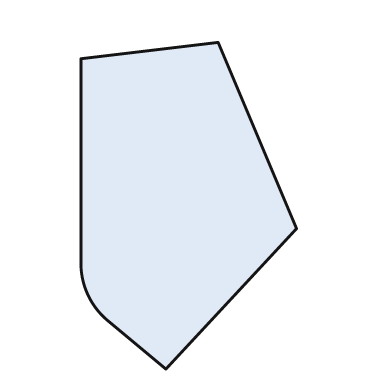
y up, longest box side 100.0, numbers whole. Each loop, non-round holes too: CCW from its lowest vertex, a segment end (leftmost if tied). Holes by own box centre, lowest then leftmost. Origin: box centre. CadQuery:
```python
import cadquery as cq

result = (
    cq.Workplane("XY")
    .moveTo(-7.0, -50.0)
    .lineTo(33.0, -7.0)
    .lineTo(9.0, 50.0)
    .lineTo(-33.0, 45.0)
    .lineTo(-33.0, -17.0)
    .threePointArc((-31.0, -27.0), (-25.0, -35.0))
    .close()
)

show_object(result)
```